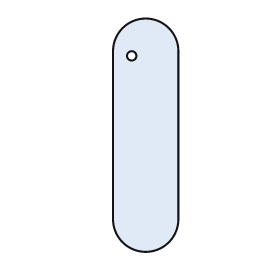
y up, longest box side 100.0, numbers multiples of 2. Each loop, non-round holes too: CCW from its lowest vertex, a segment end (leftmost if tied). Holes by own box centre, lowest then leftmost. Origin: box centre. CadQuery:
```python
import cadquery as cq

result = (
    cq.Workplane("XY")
    .moveTo(-14.0, -36.0)
    .threePointArc((0.0, -50.0), (14.0, -36.0))
    .lineTo(14.0, 36.0)
    .threePointArc((0.0, 50.0), (-14.0, 36.0))
    .close()
    .moveTo(-6.0, 34.0)
    .circle(2.0)
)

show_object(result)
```